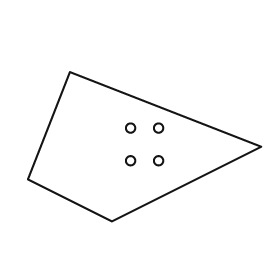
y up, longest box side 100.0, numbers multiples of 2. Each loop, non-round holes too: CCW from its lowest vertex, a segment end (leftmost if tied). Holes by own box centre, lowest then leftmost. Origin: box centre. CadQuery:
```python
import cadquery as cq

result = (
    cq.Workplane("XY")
    .moveTo(-14.0, -32.0)
    .lineTo(50.0, 0.0)
    .lineTo(-32.0, 32.0)
    .lineTo(-50.0, -14.0)
    .close()
    .moveTo(-6.0, -6.0)
    .circle(2.0)
    .moveTo(6.0, -6.0)
    .circle(2.0)
    .moveTo(-6.0, 8.0)
    .circle(2.0)
    .moveTo(6.0, 8.0)
    .circle(2.0)
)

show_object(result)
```